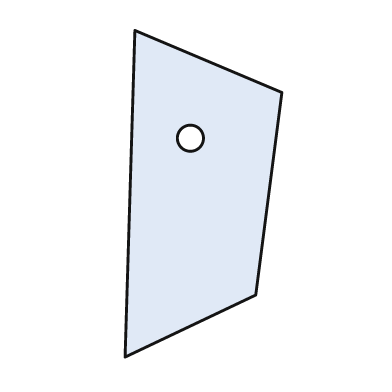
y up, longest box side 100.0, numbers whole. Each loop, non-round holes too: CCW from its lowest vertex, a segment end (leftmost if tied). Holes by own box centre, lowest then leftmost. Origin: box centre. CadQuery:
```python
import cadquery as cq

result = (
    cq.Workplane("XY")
    .moveTo(-24.0, -50.0)
    .lineTo(16.0, -31.0)
    .lineTo(24.0, 31.0)
    .lineTo(-21.0, 50.0)
    .close()
    .moveTo(-4.0, 17.0)
    .circle(4.0)
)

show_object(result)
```